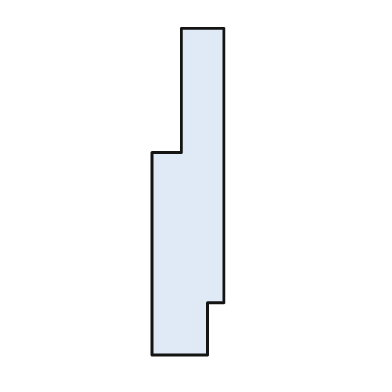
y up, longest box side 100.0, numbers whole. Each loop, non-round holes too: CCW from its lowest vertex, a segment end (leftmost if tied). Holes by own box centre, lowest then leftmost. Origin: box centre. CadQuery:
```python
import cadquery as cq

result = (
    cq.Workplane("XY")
    .moveTo(-11.0, -50.0)
    .lineTo(6.0, -50.0)
    .lineTo(6.0, -34.0)
    .lineTo(11.0, -34.0)
    .lineTo(11.0, 50.0)
    .lineTo(-2.0, 50.0)
    .lineTo(-2.0, 12.0)
    .lineTo(-11.0, 12.0)
    .close()
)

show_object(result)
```